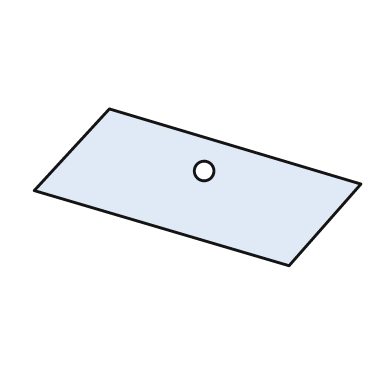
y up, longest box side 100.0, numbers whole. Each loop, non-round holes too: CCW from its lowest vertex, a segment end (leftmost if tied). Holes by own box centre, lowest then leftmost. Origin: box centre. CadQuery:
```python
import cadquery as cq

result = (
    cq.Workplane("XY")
    .moveTo(28.0, -24.0)
    .lineTo(50.0, 1.0)
    .lineTo(-27.0, 24.0)
    .lineTo(-50.0, -1.0)
    .close()
    .moveTo(2.0, 5.0)
    .circle(3.0)
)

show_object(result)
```